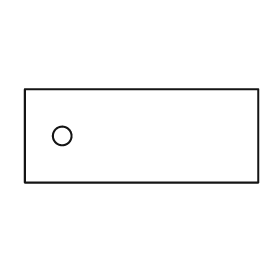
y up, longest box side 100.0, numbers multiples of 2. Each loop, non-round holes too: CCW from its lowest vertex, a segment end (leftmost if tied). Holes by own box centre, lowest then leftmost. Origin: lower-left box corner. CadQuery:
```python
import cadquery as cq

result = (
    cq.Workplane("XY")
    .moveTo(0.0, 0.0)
    .lineTo(100.0, 0.0)
    .lineTo(100.0, 40.0)
    .lineTo(0.0, 40.0)
    .close()
    .moveTo(16.0, 20.0)
    .circle(4.0)
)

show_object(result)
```